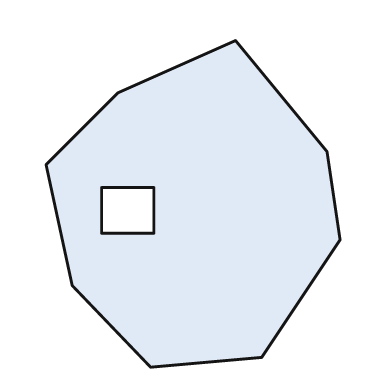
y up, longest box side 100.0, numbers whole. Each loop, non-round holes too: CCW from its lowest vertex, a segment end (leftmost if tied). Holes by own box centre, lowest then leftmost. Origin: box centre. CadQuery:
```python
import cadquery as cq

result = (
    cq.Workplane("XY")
    .moveTo(-13.0, -50.0)
    .lineTo(21.0, -47.0)
    .lineTo(45.0, -11.0)
    .lineTo(41.0, 16.0)
    .lineTo(13.0, 50.0)
    .lineTo(-23.0, 34.0)
    .lineTo(-45.0, 12.0)
    .lineTo(-37.0, -25.0)
    .close()
    .moveTo(-28.0, -9.0)
    .lineTo(-12.0, -9.0)
    .lineTo(-12.0, 5.0)
    .lineTo(-28.0, 5.0)
    .close()
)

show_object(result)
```